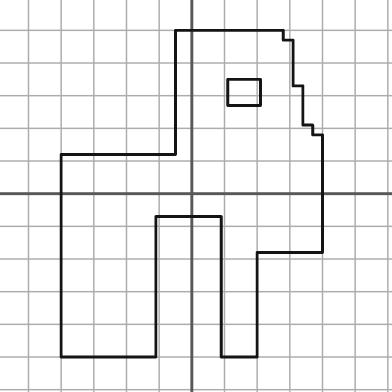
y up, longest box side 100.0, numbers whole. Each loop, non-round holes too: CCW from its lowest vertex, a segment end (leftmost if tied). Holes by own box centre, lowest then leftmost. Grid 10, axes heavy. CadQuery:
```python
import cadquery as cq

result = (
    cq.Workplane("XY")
    .moveTo(-40.0, -50.0)
    .lineTo(-11.0, -50.0)
    .lineTo(-11.0, -7.0)
    .lineTo(9.0, -7.0)
    .lineTo(9.0, -50.0)
    .lineTo(20.0, -50.0)
    .lineTo(20.0, -18.0)
    .lineTo(40.0, -18.0)
    .lineTo(40.0, 18.0)
    .lineTo(37.0, 18.0)
    .lineTo(37.0, 21.0)
    .lineTo(34.0, 21.0)
    .lineTo(34.0, 33.0)
    .lineTo(31.0, 33.0)
    .lineTo(31.0, 47.0)
    .lineTo(28.0, 47.0)
    .lineTo(28.0, 50.0)
    .lineTo(-5.0, 50.0)
    .lineTo(-5.0, 12.0)
    .lineTo(-40.0, 12.0)
    .close()
    .moveTo(11.0, 27.0)
    .lineTo(21.0, 27.0)
    .lineTo(21.0, 35.0)
    .lineTo(11.0, 35.0)
    .close()
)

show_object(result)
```